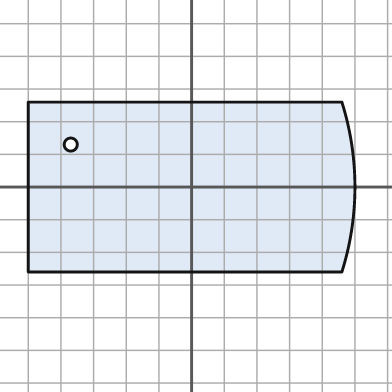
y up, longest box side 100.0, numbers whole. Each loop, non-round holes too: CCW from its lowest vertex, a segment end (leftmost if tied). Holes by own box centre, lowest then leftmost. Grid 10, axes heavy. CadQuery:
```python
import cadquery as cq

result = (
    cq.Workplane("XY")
    .moveTo(-50.0, -26.0)
    .lineTo(46.0, -26.0)
    .threePointArc((50.0, 0.0), (46.0, 26.0))
    .lineTo(-50.0, 26.0)
    .close()
    .moveTo(-37.0, 13.0)
    .circle(2.0)
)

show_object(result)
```